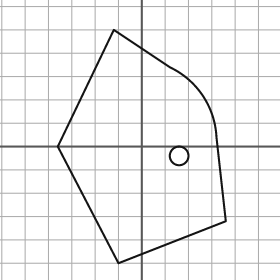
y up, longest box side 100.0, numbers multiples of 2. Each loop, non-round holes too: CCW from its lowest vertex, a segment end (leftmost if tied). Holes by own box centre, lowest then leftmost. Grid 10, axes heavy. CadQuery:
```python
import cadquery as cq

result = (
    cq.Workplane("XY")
    .moveTo(-10.0, -50.0)
    .lineTo(36.0, -32.0)
    .lineTo(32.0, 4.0)
    .threePointArc((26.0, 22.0), (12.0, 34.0))
    .lineTo(-12.0, 50.0)
    .lineTo(-36.0, 0.0)
    .close()
    .moveTo(16.0, -4.0)
    .circle(4.0)
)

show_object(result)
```